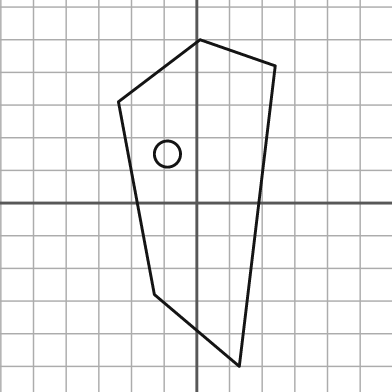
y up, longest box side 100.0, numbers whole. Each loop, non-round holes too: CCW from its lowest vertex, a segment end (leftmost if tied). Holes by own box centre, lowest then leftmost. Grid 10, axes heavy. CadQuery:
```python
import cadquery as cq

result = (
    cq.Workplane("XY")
    .moveTo(13.0, -50.0)
    .lineTo(24.0, 42.0)
    .lineTo(1.0, 50.0)
    .lineTo(-24.0, 31.0)
    .lineTo(-13.0, -28.0)
    .close()
    .moveTo(-9.0, 15.0)
    .circle(4.0)
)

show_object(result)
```